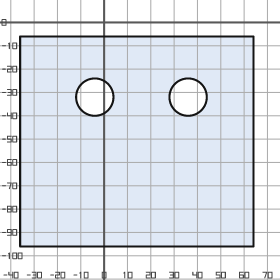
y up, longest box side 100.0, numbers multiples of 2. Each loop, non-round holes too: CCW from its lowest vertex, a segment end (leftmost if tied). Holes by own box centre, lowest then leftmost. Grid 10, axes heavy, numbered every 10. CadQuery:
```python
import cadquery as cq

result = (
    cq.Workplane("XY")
    .moveTo(-36.0, -96.0)
    .lineTo(64.0, -96.0)
    .lineTo(64.0, -6.0)
    .lineTo(-36.0, -6.0)
    .close()
    .moveTo(-4.0, -32.0)
    .circle(8.0)
    .moveTo(36.0, -32.0)
    .circle(8.0)
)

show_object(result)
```